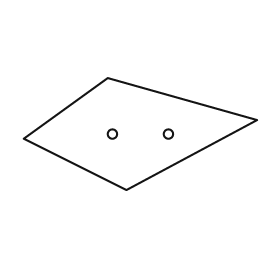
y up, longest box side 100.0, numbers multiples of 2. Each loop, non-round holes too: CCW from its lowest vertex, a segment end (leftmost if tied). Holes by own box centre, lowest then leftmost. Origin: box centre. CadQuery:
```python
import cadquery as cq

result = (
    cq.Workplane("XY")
    .moveTo(-6.0, -24.0)
    .lineTo(50.0, 6.0)
    .lineTo(-14.0, 24.0)
    .lineTo(-50.0, -2.0)
    .close()
    .moveTo(-12.0, 0.0)
    .circle(2.0)
    .moveTo(12.0, 0.0)
    .circle(2.0)
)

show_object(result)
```